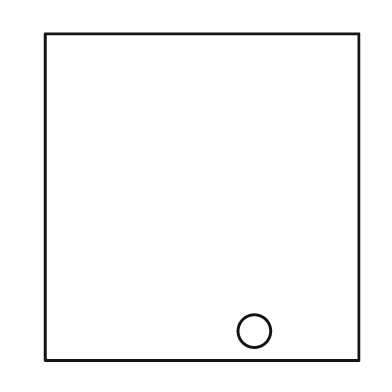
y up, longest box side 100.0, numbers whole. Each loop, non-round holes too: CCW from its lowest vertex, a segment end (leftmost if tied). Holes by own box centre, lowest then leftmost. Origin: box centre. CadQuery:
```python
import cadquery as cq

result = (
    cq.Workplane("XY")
    .moveTo(-48.0, -50.0)
    .lineTo(48.0, -50.0)
    .lineTo(48.0, 50.0)
    .lineTo(-48.0, 50.0)
    .close()
    .moveTo(16.0, -41.0)
    .circle(5.0)
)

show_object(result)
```